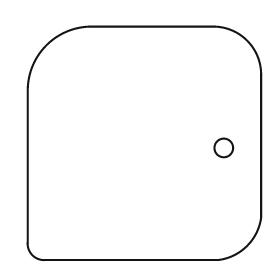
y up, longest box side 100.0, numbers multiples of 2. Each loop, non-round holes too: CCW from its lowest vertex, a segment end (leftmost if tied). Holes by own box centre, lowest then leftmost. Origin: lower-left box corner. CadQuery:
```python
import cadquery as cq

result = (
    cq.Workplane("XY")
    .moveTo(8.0, 0.0)
    .lineTo(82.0, 0.0)
    .threePointArc((94.0, 6.0), (100.0, 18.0))
    .lineTo(100.0, 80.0)
    .threePointArc((94.0, 94.0), (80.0, 100.0))
    .lineTo(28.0, 100.0)
    .threePointArc((8.0, 92.0), (0.0, 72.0))
    .lineTo(0.0, 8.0)
    .threePointArc((2.0, 2.0), (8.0, 0.0))
    .close()
    .moveTo(84.0, 48.0)
    .circle(4.0)
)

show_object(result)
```